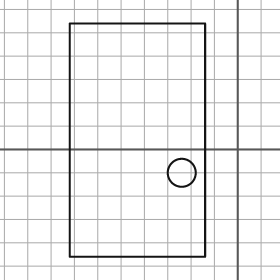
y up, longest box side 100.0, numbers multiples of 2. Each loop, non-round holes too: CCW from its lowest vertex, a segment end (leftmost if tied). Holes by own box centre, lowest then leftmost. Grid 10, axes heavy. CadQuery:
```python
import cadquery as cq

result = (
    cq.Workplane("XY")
    .moveTo(-72.0, -46.0)
    .lineTo(-14.0, -46.0)
    .lineTo(-14.0, 54.0)
    .lineTo(-72.0, 54.0)
    .close()
    .moveTo(-24.0, -10.0)
    .circle(6.0)
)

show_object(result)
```